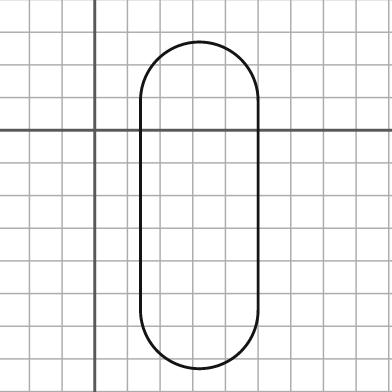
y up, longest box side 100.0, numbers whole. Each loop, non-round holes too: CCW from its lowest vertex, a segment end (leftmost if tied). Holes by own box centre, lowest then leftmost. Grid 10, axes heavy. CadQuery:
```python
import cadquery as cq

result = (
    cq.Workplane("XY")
    .moveTo(14.0, -55.0)
    .threePointArc((32.0, -73.0), (50.0, -55.0))
    .lineTo(50.0, 9.0)
    .threePointArc((32.0, 27.0), (14.0, 9.0))
    .close()
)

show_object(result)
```